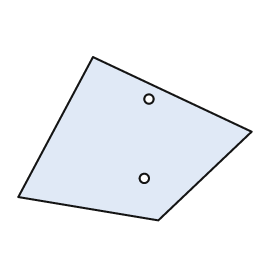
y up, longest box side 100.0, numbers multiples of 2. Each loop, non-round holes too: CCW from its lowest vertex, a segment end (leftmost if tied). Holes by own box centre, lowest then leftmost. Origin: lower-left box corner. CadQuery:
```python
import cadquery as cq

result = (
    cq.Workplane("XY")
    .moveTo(60.0, 0.0)
    .lineTo(100.0, 38.0)
    .lineTo(32.0, 70.0)
    .lineTo(0.0, 10.0)
    .close()
    .moveTo(54.0, 18.0)
    .circle(2.0)
    .moveTo(56.0, 52.0)
    .circle(2.0)
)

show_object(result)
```